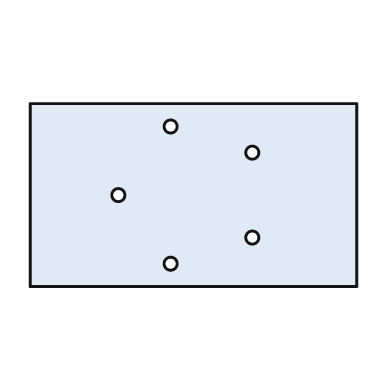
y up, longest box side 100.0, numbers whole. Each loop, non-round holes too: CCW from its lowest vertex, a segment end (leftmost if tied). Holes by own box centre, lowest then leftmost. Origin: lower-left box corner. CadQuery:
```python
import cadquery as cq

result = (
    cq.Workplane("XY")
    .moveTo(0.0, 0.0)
    .lineTo(100.0, 0.0)
    .lineTo(100.0, 56.0)
    .lineTo(0.0, 56.0)
    .close()
    .moveTo(43.0, 7.0)
    .circle(2.0)
    .moveTo(68.0, 15.0)
    .circle(2.0)
    .moveTo(27.0, 28.0)
    .circle(2.0)
    .moveTo(68.0, 41.0)
    .circle(2.0)
    .moveTo(43.0, 49.0)
    .circle(2.0)
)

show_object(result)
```